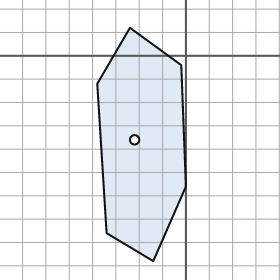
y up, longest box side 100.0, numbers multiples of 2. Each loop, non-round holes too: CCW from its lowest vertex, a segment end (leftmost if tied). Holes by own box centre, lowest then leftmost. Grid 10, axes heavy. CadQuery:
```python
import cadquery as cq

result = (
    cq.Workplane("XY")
    .moveTo(-14.0, -88.0)
    .lineTo(0.0, -56.0)
    .lineTo(-2.0, -4.0)
    .lineTo(-24.0, 12.0)
    .lineTo(-38.0, -12.0)
    .lineTo(-34.0, -76.0)
    .close()
    .moveTo(-22.0, -36.0)
    .circle(2.0)
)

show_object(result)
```